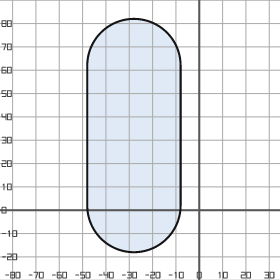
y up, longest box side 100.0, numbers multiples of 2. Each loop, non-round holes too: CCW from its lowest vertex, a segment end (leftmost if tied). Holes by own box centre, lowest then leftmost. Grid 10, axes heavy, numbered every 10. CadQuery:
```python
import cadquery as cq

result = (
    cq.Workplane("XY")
    .moveTo(-48.0, 2.0)
    .threePointArc((-28.0, -18.0), (-8.0, 2.0))
    .lineTo(-8.0, 62.0)
    .threePointArc((-28.0, 82.0), (-48.0, 62.0))
    .close()
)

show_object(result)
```